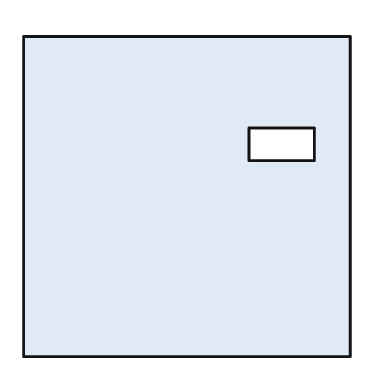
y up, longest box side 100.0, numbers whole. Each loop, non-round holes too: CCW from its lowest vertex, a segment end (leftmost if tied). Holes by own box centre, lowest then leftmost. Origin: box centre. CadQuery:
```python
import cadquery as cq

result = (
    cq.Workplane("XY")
    .moveTo(-50.0, -49.0)
    .lineTo(50.0, -49.0)
    .lineTo(50.0, 49.0)
    .lineTo(-50.0, 49.0)
    .close()
    .moveTo(19.0, 11.0)
    .lineTo(39.0, 11.0)
    .lineTo(39.0, 21.0)
    .lineTo(19.0, 21.0)
    .close()
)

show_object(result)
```